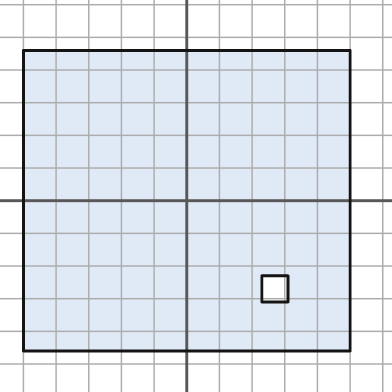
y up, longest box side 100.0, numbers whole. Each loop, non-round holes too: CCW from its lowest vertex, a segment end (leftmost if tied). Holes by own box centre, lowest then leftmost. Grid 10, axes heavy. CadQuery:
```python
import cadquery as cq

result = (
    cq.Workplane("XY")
    .moveTo(-50.0, -46.0)
    .lineTo(50.0, -46.0)
    .lineTo(50.0, 46.0)
    .lineTo(-50.0, 46.0)
    .close()
    .moveTo(23.0, -31.0)
    .lineTo(31.0, -31.0)
    .lineTo(31.0, -23.0)
    .lineTo(23.0, -23.0)
    .close()
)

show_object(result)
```